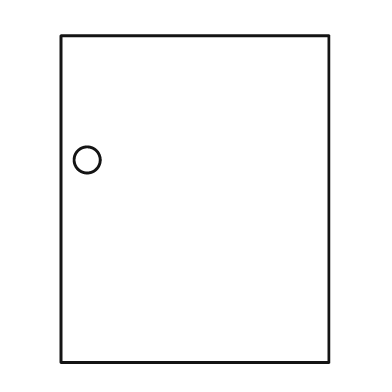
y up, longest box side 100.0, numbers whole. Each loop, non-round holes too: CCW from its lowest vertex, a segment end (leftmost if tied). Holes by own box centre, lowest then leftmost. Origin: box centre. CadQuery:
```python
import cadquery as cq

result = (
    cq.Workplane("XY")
    .moveTo(-41.0, -50.0)
    .lineTo(41.0, -50.0)
    .lineTo(41.0, 50.0)
    .lineTo(-41.0, 50.0)
    .close()
    .moveTo(-33.0, 12.0)
    .circle(4.0)
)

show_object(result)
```